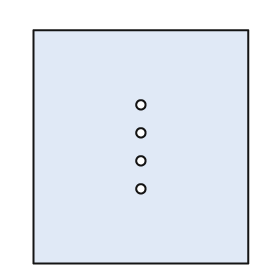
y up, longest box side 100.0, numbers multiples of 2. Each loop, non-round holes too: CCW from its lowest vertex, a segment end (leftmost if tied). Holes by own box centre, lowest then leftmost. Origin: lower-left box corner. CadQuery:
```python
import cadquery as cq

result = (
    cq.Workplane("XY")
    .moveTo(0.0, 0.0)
    .lineTo(92.0, 0.0)
    .lineTo(92.0, 100.0)
    .lineTo(0.0, 100.0)
    .close()
    .moveTo(46.0, 32.0)
    .circle(2.0)
    .moveTo(46.0, 44.0)
    .circle(2.0)
    .moveTo(46.0, 56.0)
    .circle(2.0)
    .moveTo(46.0, 68.0)
    .circle(2.0)
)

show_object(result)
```